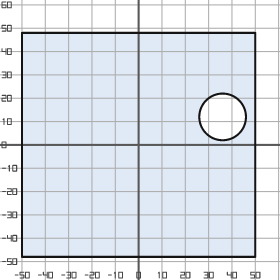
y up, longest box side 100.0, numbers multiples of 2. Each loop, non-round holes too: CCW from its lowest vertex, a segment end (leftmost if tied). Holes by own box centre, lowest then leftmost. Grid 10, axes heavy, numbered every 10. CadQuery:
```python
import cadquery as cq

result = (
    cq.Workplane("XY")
    .moveTo(-50.0, -48.0)
    .lineTo(50.0, -48.0)
    .lineTo(50.0, 48.0)
    .lineTo(-50.0, 48.0)
    .close()
    .moveTo(36.0, 12.0)
    .circle(10.0)
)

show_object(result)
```